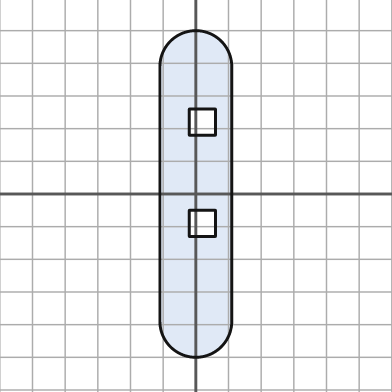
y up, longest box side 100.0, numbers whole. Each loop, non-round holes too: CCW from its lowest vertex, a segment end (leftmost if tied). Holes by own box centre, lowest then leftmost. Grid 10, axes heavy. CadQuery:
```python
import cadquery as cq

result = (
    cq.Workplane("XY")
    .moveTo(-11.0, -39.0)
    .threePointArc((0.0, -50.0), (11.0, -39.0))
    .lineTo(11.0, 39.0)
    .threePointArc((0.0, 50.0), (-11.0, 39.0))
    .close()
    .moveTo(-2.0, -13.0)
    .lineTo(6.0, -13.0)
    .lineTo(6.0, -5.0)
    .lineTo(-2.0, -5.0)
    .close()
    .moveTo(-2.0, 18.0)
    .lineTo(6.0, 18.0)
    .lineTo(6.0, 26.0)
    .lineTo(-2.0, 26.0)
    .close()
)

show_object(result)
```